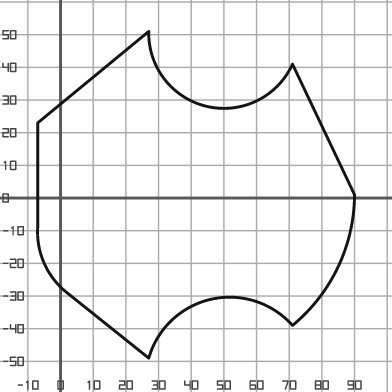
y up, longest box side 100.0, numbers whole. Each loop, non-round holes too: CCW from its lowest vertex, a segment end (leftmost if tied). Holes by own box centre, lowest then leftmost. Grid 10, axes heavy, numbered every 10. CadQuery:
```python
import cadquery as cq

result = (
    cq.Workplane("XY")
    .moveTo(27.0, -49.0)
    .threePointArc((46.0, -31.0), (71.0, -39.0))
    .threePointArc((85.0, -21.0), (90.0, 1.0))
    .lineTo(71.0, 41.0)
    .threePointArc((45.0, 28.0), (27.0, 51.0))
    .lineTo(-7.0, 23.0)
    .lineTo(-7.0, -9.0)
    .threePointArc((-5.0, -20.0), (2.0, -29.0))
    .close()
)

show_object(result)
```